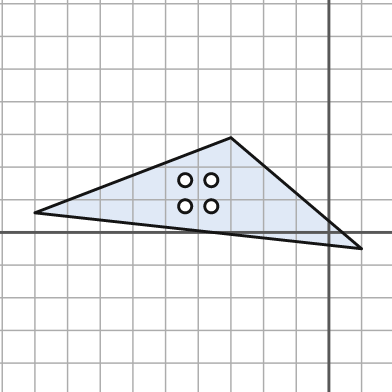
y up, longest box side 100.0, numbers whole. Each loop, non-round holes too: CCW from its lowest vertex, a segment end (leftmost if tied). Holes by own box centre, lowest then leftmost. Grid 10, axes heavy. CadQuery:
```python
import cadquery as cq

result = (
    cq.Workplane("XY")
    .moveTo(10.0, -5.0)
    .lineTo(-30.0, 29.0)
    .lineTo(-90.0, 6.0)
    .close()
    .moveTo(-44.0, 8.0)
    .circle(2.0)
    .moveTo(-36.0, 8.0)
    .circle(2.0)
    .moveTo(-44.0, 16.0)
    .circle(2.0)
    .moveTo(-36.0, 16.0)
    .circle(2.0)
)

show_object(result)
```